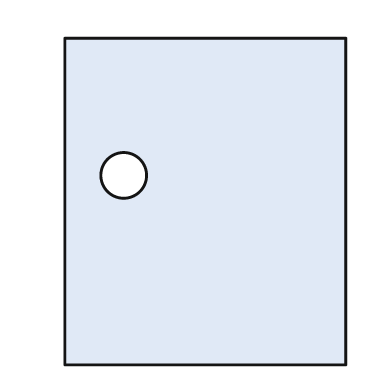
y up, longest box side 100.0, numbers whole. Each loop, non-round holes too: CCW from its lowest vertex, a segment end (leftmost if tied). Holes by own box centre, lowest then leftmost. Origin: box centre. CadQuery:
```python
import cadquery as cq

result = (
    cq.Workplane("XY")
    .moveTo(-43.0, -50.0)
    .lineTo(43.0, -50.0)
    .lineTo(43.0, 50.0)
    .lineTo(-43.0, 50.0)
    .close()
    .moveTo(-25.0, 8.0)
    .circle(7.0)
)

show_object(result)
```